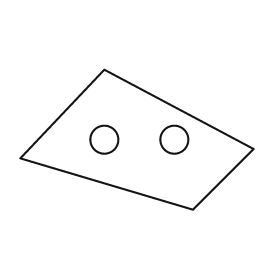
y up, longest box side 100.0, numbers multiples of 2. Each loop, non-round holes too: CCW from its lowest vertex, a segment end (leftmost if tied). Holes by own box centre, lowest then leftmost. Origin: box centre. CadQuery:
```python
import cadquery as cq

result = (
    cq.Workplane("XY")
    .moveTo(24.0, -30.0)
    .lineTo(50.0, -4.0)
    .lineTo(-14.0, 30.0)
    .lineTo(-50.0, -8.0)
    .close()
    .moveTo(-14.0, 0.0)
    .circle(6.0)
    .moveTo(16.0, 0.0)
    .circle(6.0)
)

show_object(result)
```